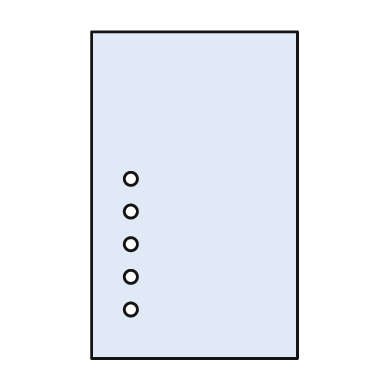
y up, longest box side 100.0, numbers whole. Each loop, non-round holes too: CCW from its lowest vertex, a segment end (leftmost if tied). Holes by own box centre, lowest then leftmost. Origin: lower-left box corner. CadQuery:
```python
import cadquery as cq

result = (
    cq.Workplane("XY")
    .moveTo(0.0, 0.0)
    .lineTo(63.0, 0.0)
    .lineTo(63.0, 100.0)
    .lineTo(0.0, 100.0)
    .close()
    .moveTo(12.0, 15.0)
    .circle(2.0)
    .moveTo(12.0, 25.0)
    .circle(2.0)
    .moveTo(12.0, 35.0)
    .circle(2.0)
    .moveTo(12.0, 45.0)
    .circle(2.0)
    .moveTo(12.0, 55.0)
    .circle(2.0)
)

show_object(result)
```